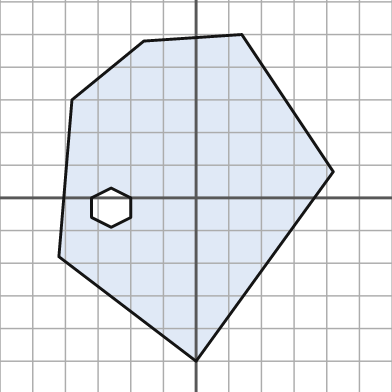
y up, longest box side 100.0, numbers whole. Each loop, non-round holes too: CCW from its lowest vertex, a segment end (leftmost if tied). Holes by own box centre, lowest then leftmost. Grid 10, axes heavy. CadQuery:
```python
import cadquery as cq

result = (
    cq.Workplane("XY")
    .moveTo(0.0, -50.0)
    .lineTo(42.0, 8.0)
    .lineTo(14.0, 50.0)
    .lineTo(-16.0, 48.0)
    .lineTo(-38.0, 30.0)
    .lineTo(-42.0, -18.0)
    .close()
    .moveTo(-26.0, -9.0)
    .lineTo(-20.0, -6.0)
    .lineTo(-20.0, 0.0)
    .lineTo(-26.0, 3.0)
    .lineTo(-32.0, 0.0)
    .lineTo(-32.0, -6.0)
    .close()
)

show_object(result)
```